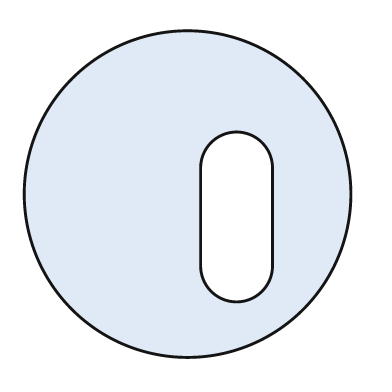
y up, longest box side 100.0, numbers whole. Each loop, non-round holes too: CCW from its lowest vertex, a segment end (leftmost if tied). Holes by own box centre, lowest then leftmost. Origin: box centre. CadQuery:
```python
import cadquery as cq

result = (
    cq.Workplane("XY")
    .moveTo(0.0, 0.0)
    .circle(50.0)
    .moveTo(4.0, -22.0)
    .threePointArc((15.0, -33.0), (26.0, -22.0))
    .lineTo(26.0, 8.0)
    .threePointArc((15.0, 19.0), (4.0, 8.0))
    .close()
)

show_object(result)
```